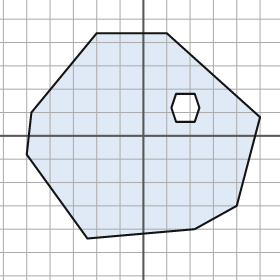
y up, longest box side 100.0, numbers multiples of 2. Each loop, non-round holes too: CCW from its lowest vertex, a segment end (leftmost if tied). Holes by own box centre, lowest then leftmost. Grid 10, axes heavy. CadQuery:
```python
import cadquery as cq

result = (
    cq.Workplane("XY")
    .moveTo(-24.0, -44.0)
    .lineTo(22.0, -40.0)
    .lineTo(40.0, -30.0)
    .lineTo(50.0, 8.0)
    .lineTo(10.0, 44.0)
    .lineTo(-20.0, 44.0)
    .lineTo(-48.0, 10.0)
    .lineTo(-50.0, -8.0)
    .close()
    .moveTo(14.0, 6.0)
    .lineTo(22.0, 6.0)
    .lineTo(24.0, 12.0)
    .lineTo(22.0, 18.0)
    .lineTo(14.0, 18.0)
    .lineTo(12.0, 12.0)
    .close()
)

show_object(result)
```